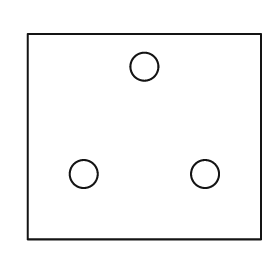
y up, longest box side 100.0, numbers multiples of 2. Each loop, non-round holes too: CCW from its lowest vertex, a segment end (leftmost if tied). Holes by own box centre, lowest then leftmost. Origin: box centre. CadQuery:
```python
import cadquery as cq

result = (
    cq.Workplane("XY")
    .moveTo(-50.0, -44.0)
    .lineTo(50.0, -44.0)
    .lineTo(50.0, 44.0)
    .lineTo(-50.0, 44.0)
    .close()
    .moveTo(-26.0, -16.0)
    .circle(6.0)
    .moveTo(26.0, -16.0)
    .circle(6.0)
    .moveTo(0.0, 30.0)
    .circle(6.0)
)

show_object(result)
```